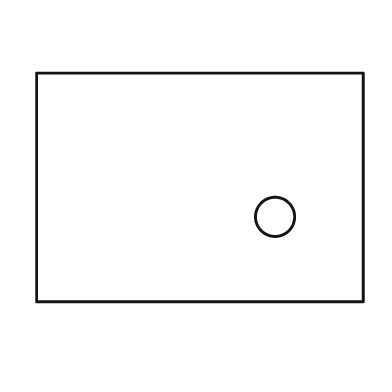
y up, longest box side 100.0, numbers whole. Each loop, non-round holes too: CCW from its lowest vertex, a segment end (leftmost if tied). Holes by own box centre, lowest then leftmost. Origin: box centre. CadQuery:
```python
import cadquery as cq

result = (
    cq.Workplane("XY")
    .moveTo(-50.0, -35.0)
    .lineTo(50.0, -35.0)
    .lineTo(50.0, 35.0)
    .lineTo(-50.0, 35.0)
    .close()
    .moveTo(23.0, -9.0)
    .circle(6.0)
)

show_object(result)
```